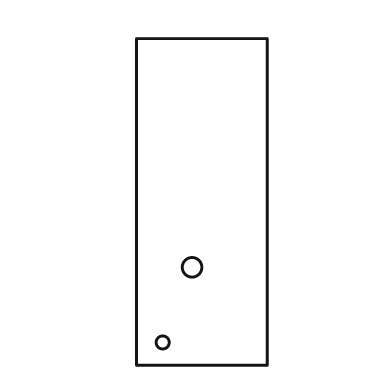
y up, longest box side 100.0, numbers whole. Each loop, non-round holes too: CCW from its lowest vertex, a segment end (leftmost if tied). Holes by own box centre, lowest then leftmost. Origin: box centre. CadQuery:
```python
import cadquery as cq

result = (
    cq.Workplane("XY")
    .moveTo(-20.0, -50.0)
    .lineTo(20.0, -50.0)
    .lineTo(20.0, 50.0)
    .lineTo(-20.0, 50.0)
    .close()
    .moveTo(-12.0, -43.0)
    .circle(2.0)
    .moveTo(-3.0, -20.0)
    .circle(3.0)
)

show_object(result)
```